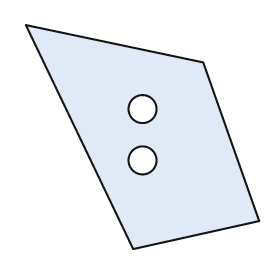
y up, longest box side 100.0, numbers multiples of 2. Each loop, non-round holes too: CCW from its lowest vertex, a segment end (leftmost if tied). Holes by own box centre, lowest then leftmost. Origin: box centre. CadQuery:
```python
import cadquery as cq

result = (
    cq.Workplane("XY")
    .moveTo(-4.0, -48.0)
    .lineTo(50.0, -36.0)
    .lineTo(26.0, 32.0)
    .lineTo(-50.0, 48.0)
    .close()
    .moveTo(0.0, -10.0)
    .circle(6.0)
    .moveTo(0.0, 12.0)
    .circle(6.0)
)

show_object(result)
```